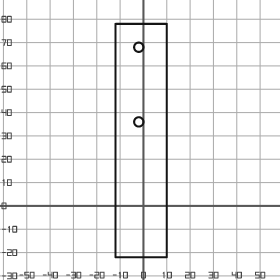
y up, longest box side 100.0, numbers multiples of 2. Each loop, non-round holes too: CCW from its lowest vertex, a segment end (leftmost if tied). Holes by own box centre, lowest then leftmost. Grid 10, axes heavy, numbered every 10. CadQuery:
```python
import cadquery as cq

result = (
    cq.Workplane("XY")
    .moveTo(-12.0, -22.0)
    .lineTo(10.0, -22.0)
    .lineTo(10.0, 78.0)
    .lineTo(-12.0, 78.0)
    .close()
    .moveTo(-2.0, 36.0)
    .circle(2.0)
    .moveTo(-2.0, 68.0)
    .circle(2.0)
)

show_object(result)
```